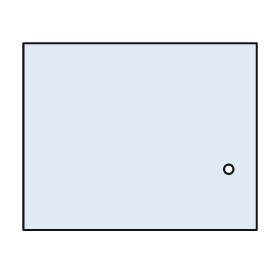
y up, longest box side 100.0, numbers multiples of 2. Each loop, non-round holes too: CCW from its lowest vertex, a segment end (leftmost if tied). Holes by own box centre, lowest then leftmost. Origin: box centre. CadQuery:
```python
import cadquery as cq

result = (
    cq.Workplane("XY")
    .moveTo(-50.0, -40.0)
    .lineTo(50.0, -40.0)
    .lineTo(50.0, 40.0)
    .lineTo(-50.0, 40.0)
    .close()
    .moveTo(38.0, -14.0)
    .circle(2.0)
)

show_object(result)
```